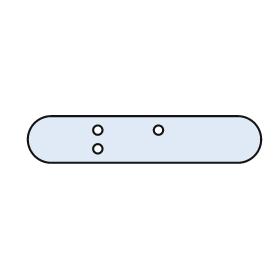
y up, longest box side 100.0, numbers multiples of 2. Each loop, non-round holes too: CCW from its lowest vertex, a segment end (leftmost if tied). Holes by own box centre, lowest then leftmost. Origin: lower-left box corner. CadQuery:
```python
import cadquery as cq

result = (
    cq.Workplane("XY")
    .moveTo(10.0, 0.0)
    .lineTo(90.0, 0.0)
    .threePointArc((100.0, 10.0), (90.0, 20.0))
    .lineTo(10.0, 20.0)
    .threePointArc((0.0, 10.0), (10.0, 0.0))
    .close()
    .moveTo(30.0, 6.0)
    .circle(2.0)
    .moveTo(30.0, 14.0)
    .circle(2.0)
    .moveTo(56.0, 14.0)
    .circle(2.0)
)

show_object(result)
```